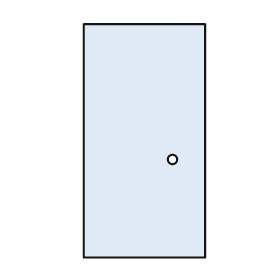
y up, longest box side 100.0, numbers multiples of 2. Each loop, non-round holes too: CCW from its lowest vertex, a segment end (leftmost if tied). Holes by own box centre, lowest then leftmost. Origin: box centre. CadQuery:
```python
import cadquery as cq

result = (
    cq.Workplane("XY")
    .moveTo(-26.0, -50.0)
    .lineTo(26.0, -50.0)
    .lineTo(26.0, 50.0)
    .lineTo(-26.0, 50.0)
    .close()
    .moveTo(12.0, -8.0)
    .circle(2.0)
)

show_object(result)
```